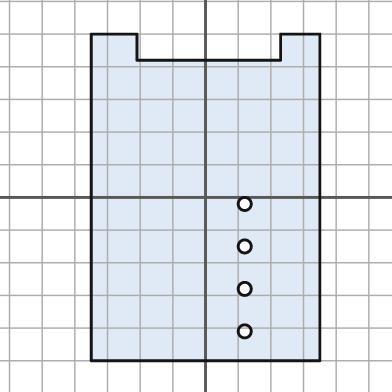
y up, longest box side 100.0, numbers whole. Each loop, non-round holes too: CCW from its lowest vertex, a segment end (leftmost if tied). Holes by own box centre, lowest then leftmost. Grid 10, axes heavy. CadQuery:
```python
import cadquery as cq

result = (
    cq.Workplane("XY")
    .moveTo(-35.0, -50.0)
    .lineTo(35.0, -50.0)
    .lineTo(35.0, 50.0)
    .lineTo(23.0, 50.0)
    .lineTo(23.0, 42.0)
    .lineTo(-21.0, 42.0)
    .lineTo(-21.0, 50.0)
    .lineTo(-35.0, 50.0)
    .close()
    .moveTo(12.0, -41.0)
    .circle(2.0)
    .moveTo(12.0, -28.0)
    .circle(2.0)
    .moveTo(12.0, -15.0)
    .circle(2.0)
    .moveTo(12.0, -2.0)
    .circle(2.0)
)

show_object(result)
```